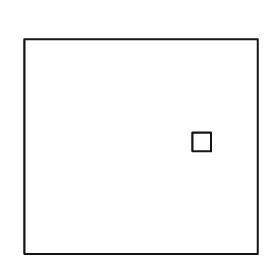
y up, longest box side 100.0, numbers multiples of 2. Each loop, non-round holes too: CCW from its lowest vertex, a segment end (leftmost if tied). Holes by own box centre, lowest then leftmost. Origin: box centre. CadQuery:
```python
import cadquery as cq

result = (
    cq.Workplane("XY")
    .moveTo(-50.0, -46.0)
    .lineTo(50.0, -46.0)
    .lineTo(50.0, 46.0)
    .lineTo(-50.0, 46.0)
    .close()
    .moveTo(22.0, -2.0)
    .lineTo(30.0, -2.0)
    .lineTo(30.0, 6.0)
    .lineTo(22.0, 6.0)
    .close()
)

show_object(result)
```